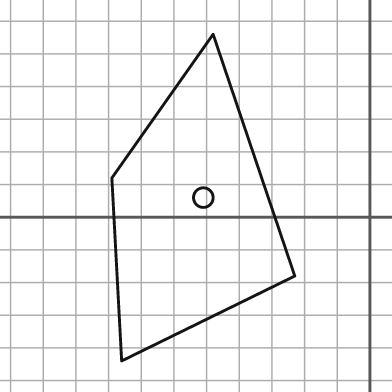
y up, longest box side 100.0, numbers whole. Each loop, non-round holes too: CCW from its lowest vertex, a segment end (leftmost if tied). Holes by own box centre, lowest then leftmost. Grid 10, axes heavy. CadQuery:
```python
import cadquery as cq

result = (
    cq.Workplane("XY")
    .moveTo(-76.0, -44.0)
    .lineTo(-23.0, -18.0)
    .lineTo(-48.0, 56.0)
    .lineTo(-79.0, 12.0)
    .close()
    .moveTo(-51.0, 6.0)
    .circle(3.0)
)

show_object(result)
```